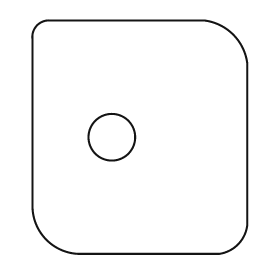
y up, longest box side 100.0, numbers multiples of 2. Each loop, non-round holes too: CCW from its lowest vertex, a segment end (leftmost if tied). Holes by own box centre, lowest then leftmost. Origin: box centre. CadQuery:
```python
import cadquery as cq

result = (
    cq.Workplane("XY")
    .moveTo(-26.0, -50.0)
    .lineTo(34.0, -50.0)
    .threePointArc((42.0, -46.0), (46.0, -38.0))
    .lineTo(46.0, 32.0)
    .threePointArc((40.0, 44.0), (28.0, 50.0))
    .lineTo(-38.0, 50.0)
    .threePointArc((-44.0, 48.0), (-46.0, 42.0))
    .lineTo(-46.0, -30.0)
    .threePointArc((-40.0, -44.0), (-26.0, -50.0))
    .close()
    .moveTo(-12.0, 0.0)
    .circle(10.0)
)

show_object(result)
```